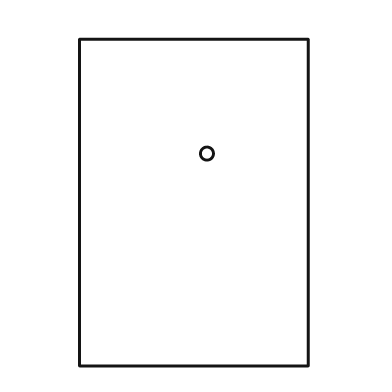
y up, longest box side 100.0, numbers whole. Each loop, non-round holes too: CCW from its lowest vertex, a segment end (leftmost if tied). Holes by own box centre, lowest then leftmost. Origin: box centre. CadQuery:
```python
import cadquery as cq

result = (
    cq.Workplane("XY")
    .moveTo(-35.0, -50.0)
    .lineTo(35.0, -50.0)
    .lineTo(35.0, 50.0)
    .lineTo(-35.0, 50.0)
    .close()
    .moveTo(4.0, 15.0)
    .circle(2.0)
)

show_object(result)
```